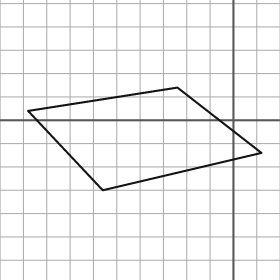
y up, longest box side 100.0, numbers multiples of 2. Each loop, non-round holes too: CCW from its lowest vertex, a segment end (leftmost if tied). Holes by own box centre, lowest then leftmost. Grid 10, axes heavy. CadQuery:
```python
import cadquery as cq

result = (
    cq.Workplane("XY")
    .moveTo(-56.0, -30.0)
    .lineTo(12.0, -14.0)
    .lineTo(-24.0, 14.0)
    .lineTo(-88.0, 4.0)
    .close()
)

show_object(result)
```